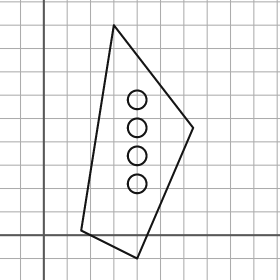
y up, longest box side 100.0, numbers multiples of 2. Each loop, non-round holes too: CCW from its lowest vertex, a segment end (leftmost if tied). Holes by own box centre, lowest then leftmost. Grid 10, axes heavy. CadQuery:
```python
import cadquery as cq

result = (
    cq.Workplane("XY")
    .moveTo(40.0, -10.0)
    .lineTo(64.0, 46.0)
    .lineTo(30.0, 90.0)
    .lineTo(16.0, 2.0)
    .close()
    .moveTo(40.0, 22.0)
    .circle(4.0)
    .moveTo(40.0, 34.0)
    .circle(4.0)
    .moveTo(40.0, 46.0)
    .circle(4.0)
    .moveTo(40.0, 58.0)
    .circle(4.0)
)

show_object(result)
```